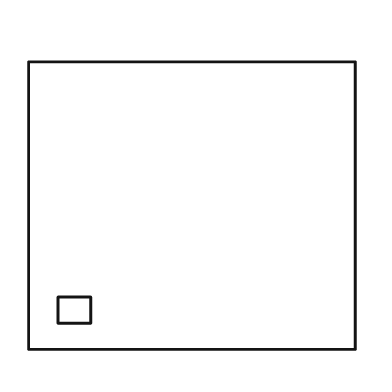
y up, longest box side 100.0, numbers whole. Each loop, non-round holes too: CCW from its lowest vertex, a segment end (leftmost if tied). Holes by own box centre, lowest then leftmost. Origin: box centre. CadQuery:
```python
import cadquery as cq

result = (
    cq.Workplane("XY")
    .moveTo(-50.0, -44.0)
    .lineTo(50.0, -44.0)
    .lineTo(50.0, 44.0)
    .lineTo(-50.0, 44.0)
    .close()
    .moveTo(-41.0, -36.0)
    .lineTo(-31.0, -36.0)
    .lineTo(-31.0, -28.0)
    .lineTo(-41.0, -28.0)
    .close()
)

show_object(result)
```